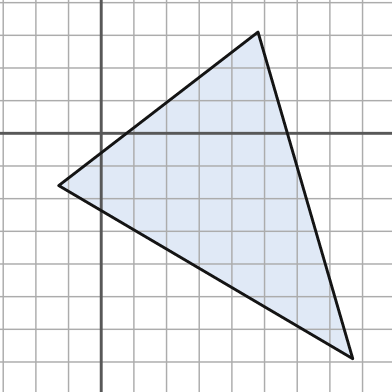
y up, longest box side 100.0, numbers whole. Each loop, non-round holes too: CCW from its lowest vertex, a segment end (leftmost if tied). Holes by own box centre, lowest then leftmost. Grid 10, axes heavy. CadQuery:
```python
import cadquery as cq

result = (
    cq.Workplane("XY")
    .moveTo(77.0, -69.0)
    .lineTo(48.0, 31.0)
    .lineTo(-13.0, -16.0)
    .close()
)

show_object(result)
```